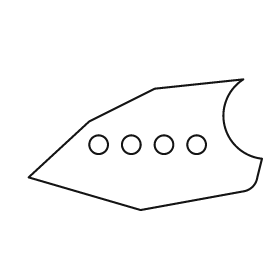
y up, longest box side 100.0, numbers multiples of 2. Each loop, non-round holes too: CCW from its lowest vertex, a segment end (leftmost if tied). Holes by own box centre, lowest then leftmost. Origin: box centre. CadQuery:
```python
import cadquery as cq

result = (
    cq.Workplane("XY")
    .moveTo(-2.0, -28.0)
    .lineTo(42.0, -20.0)
    .threePointArc((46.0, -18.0), (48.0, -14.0))
    .lineTo(50.0, -6.0)
    .threePointArc((34.0, 8.0), (42.0, 28.0))
    .lineTo(4.0, 24.0)
    .lineTo(-24.0, 10.0)
    .lineTo(-50.0, -14.0)
    .close()
    .moveTo(-20.0, 0.0)
    .circle(4.0)
    .moveTo(-6.0, 0.0)
    .circle(4.0)
    .moveTo(8.0, 0.0)
    .circle(4.0)
    .moveTo(22.0, 0.0)
    .circle(4.0)
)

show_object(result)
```